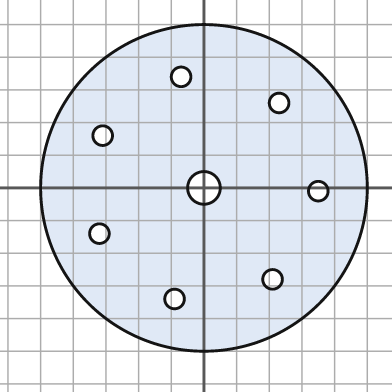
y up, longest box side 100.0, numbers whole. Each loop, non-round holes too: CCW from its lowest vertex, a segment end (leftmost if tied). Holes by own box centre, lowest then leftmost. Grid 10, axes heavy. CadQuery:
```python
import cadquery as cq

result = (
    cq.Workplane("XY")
    .moveTo(0.0, 0.0)
    .circle(50.0)
    .moveTo(-9.0, -34.0)
    .circle(3.0)
    .moveTo(21.0, -28.0)
    .circle(3.0)
    .moveTo(-32.0, -14.0)
    .circle(3.0)
    .moveTo(35.0, -1.0)
    .circle(3.0)
    .moveTo(0.0, 0.0)
    .circle(5.0)
    .moveTo(-31.0, 16.0)
    .circle(3.0)
    .moveTo(23.0, 26.0)
    .circle(3.0)
    .moveTo(-7.0, 34.0)
    .circle(3.0)
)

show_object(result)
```